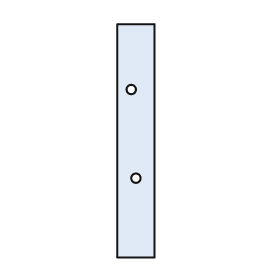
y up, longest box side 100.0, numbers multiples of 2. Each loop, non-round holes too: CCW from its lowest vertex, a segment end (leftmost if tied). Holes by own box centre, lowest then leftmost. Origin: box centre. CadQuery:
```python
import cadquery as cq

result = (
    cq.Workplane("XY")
    .moveTo(-8.0, -50.0)
    .lineTo(8.0, -50.0)
    .lineTo(8.0, 50.0)
    .lineTo(-8.0, 50.0)
    .close()
    .moveTo(0.0, -16.0)
    .circle(2.0)
    .moveTo(-2.0, 22.0)
    .circle(2.0)
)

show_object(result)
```